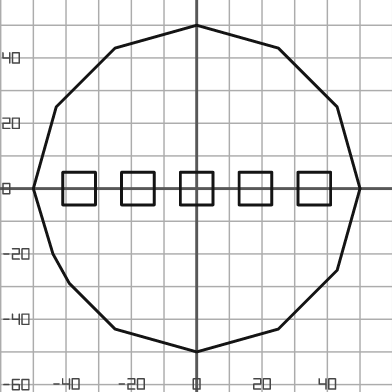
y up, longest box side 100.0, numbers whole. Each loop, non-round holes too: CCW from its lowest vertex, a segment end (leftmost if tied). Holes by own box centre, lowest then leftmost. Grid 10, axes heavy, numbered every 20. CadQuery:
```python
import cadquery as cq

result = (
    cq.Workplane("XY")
    .moveTo(0.0, -50.0)
    .lineTo(25.0, -43.0)
    .lineTo(43.0, -25.0)
    .lineTo(50.0, 0.0)
    .lineTo(43.0, 25.0)
    .lineTo(25.0, 43.0)
    .lineTo(0.0, 50.0)
    .lineTo(-25.0, 43.0)
    .lineTo(-43.0, 25.0)
    .lineTo(-50.0, 0.0)
    .lineTo(-44.0, -20.0)
    .lineTo(-39.0, -29.0)
    .lineTo(-25.0, -43.0)
    .close()
    .moveTo(-41.0, -5.0)
    .lineTo(-31.0, -5.0)
    .lineTo(-31.0, 5.0)
    .lineTo(-41.0, 5.0)
    .close()
    .moveTo(-23.0, -5.0)
    .lineTo(-13.0, -5.0)
    .lineTo(-13.0, 5.0)
    .lineTo(-23.0, 5.0)
    .close()
    .moveTo(-5.0, -5.0)
    .lineTo(5.0, -5.0)
    .lineTo(5.0, 5.0)
    .lineTo(-5.0, 5.0)
    .close()
    .moveTo(13.0, -5.0)
    .lineTo(23.0, -5.0)
    .lineTo(23.0, 5.0)
    .lineTo(13.0, 5.0)
    .close()
    .moveTo(31.0, -5.0)
    .lineTo(41.0, -5.0)
    .lineTo(41.0, 5.0)
    .lineTo(31.0, 5.0)
    .close()
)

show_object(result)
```